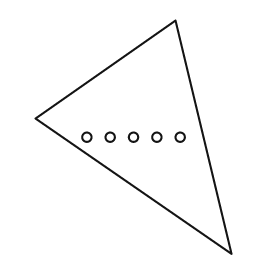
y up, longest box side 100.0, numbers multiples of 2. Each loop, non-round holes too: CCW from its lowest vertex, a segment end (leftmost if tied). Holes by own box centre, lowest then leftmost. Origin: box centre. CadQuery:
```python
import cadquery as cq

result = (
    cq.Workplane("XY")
    .moveTo(42.0, -50.0)
    .lineTo(18.0, 50.0)
    .lineTo(-42.0, 8.0)
    .close()
    .moveTo(-20.0, 0.0)
    .circle(2.0)
    .moveTo(-10.0, 0.0)
    .circle(2.0)
    .moveTo(0.0, 0.0)
    .circle(2.0)
    .moveTo(10.0, 0.0)
    .circle(2.0)
    .moveTo(20.0, 0.0)
    .circle(2.0)
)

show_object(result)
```